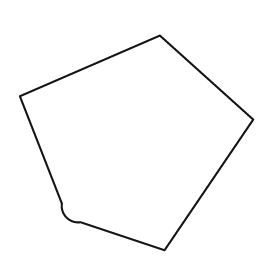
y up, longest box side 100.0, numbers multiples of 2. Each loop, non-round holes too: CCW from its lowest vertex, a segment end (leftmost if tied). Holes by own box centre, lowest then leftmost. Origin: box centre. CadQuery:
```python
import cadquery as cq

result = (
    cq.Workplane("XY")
    .moveTo(12.0, -46.0)
    .lineTo(50.0, 10.0)
    .lineTo(10.0, 46.0)
    .lineTo(-50.0, 20.0)
    .lineTo(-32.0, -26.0)
    .threePointArc((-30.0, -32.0), (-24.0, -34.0))
    .close()
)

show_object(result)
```